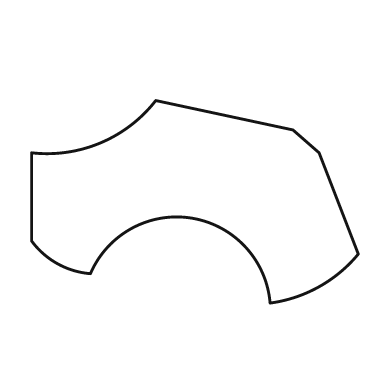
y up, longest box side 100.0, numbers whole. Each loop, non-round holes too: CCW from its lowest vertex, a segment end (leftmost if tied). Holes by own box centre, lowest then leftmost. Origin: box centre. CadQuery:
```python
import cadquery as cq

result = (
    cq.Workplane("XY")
    .moveTo(23.0, -31.0)
    .threePointArc((38.0, -26.0), (50.0, -16.0))
    .lineTo(38.0, 15.0)
    .lineTo(30.0, 22.0)
    .lineTo(-12.0, 31.0)
    .threePointArc((-29.0, 18.0), (-50.0, 15.0))
    .lineTo(-50.0, -12.0)
    .threePointArc((-42.0, -19.0), (-32.0, -22.0))
    .threePointArc((-1.0, -5.0), (23.0, -31.0))
    .close()
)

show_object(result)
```